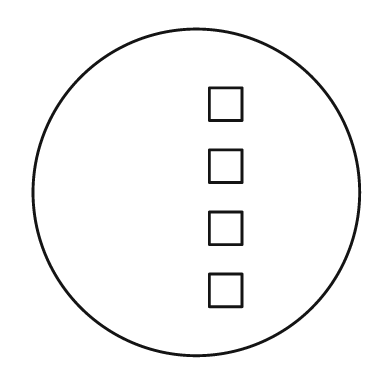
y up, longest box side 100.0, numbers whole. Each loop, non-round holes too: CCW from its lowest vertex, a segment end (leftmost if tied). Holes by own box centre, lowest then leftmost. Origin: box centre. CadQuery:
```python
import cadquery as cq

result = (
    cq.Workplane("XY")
    .moveTo(0.0, 0.0)
    .circle(50.0)
    .moveTo(4.0, -35.0)
    .lineTo(14.0, -35.0)
    .lineTo(14.0, -25.0)
    .lineTo(4.0, -25.0)
    .close()
    .moveTo(4.0, -16.0)
    .lineTo(14.0, -16.0)
    .lineTo(14.0, -6.0)
    .lineTo(4.0, -6.0)
    .close()
    .moveTo(4.0, 3.0)
    .lineTo(14.0, 3.0)
    .lineTo(14.0, 13.0)
    .lineTo(4.0, 13.0)
    .close()
    .moveTo(4.0, 22.0)
    .lineTo(14.0, 22.0)
    .lineTo(14.0, 32.0)
    .lineTo(4.0, 32.0)
    .close()
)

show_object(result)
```